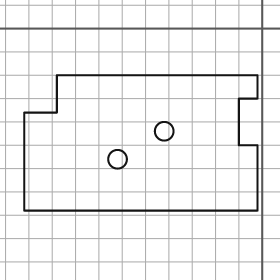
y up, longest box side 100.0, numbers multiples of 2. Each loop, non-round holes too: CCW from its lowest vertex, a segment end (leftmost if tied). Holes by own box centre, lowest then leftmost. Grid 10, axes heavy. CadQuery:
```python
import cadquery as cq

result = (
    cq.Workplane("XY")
    .moveTo(-102.0, -78.0)
    .lineTo(-2.0, -78.0)
    .lineTo(-2.0, -50.0)
    .lineTo(-10.0, -50.0)
    .lineTo(-10.0, -30.0)
    .lineTo(-2.0, -30.0)
    .lineTo(-2.0, -20.0)
    .lineTo(-88.0, -20.0)
    .lineTo(-88.0, -36.0)
    .lineTo(-102.0, -36.0)
    .close()
    .moveTo(-62.0, -56.0)
    .circle(4.0)
    .moveTo(-42.0, -44.0)
    .circle(4.0)
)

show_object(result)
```